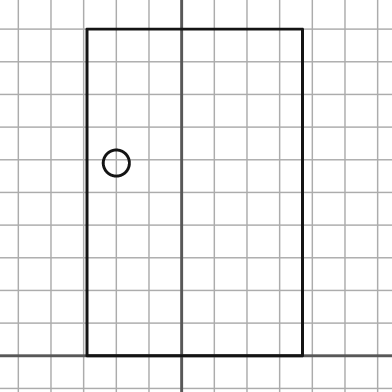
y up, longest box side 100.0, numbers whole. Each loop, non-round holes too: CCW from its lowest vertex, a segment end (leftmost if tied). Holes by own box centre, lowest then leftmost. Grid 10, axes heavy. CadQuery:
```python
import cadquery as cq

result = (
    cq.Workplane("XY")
    .moveTo(-29.0, 0.0)
    .lineTo(37.0, 0.0)
    .lineTo(37.0, 100.0)
    .lineTo(-29.0, 100.0)
    .close()
    .moveTo(-20.0, 59.0)
    .circle(4.0)
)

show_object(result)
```